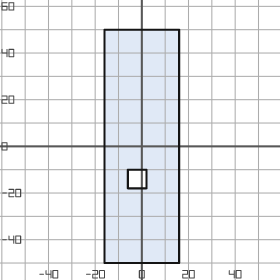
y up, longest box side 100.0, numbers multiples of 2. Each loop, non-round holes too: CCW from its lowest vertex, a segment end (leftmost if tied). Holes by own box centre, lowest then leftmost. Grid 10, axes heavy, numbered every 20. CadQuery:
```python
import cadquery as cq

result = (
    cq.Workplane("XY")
    .moveTo(-16.0, -50.0)
    .lineTo(16.0, -50.0)
    .lineTo(16.0, 50.0)
    .lineTo(-16.0, 50.0)
    .close()
    .moveTo(-6.0, -18.0)
    .lineTo(2.0, -18.0)
    .lineTo(2.0, -10.0)
    .lineTo(-6.0, -10.0)
    .close()
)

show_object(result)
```